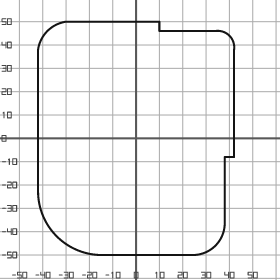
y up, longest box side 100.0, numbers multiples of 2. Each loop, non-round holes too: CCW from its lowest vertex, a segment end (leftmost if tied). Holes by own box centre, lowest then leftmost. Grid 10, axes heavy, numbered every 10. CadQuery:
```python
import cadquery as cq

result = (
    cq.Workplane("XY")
    .moveTo(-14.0, -50.0)
    .lineTo(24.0, -50.0)
    .threePointArc((34.0, -46.0), (38.0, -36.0))
    .lineTo(38.0, -8.0)
    .lineTo(42.0, -8.0)
    .lineTo(42.0, 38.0)
    .threePointArc((40.0, 44.0), (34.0, 46.0))
    .lineTo(10.0, 46.0)
    .lineTo(10.0, 50.0)
    .lineTo(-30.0, 50.0)
    .threePointArc((-38.0, 46.0), (-42.0, 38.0))
    .lineTo(-42.0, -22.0)
    .threePointArc((-34.0, -42.0), (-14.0, -50.0))
    .close()
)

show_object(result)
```